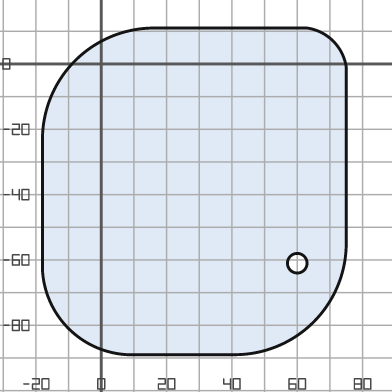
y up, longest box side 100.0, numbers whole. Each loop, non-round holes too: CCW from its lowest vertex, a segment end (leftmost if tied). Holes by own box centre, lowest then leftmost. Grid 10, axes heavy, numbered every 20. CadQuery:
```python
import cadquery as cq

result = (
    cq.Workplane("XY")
    .moveTo(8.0, -89.0)
    .lineTo(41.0, -89.0)
    .threePointArc((65.0, -79.0), (75.0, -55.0))
    .lineTo(75.0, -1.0)
    .threePointArc((71.0, 7.0), (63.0, 11.0))
    .lineTo(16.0, 11.0)
    .threePointArc((-8.0, 1.0), (-18.0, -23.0))
    .lineTo(-18.0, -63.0)
    .threePointArc((-10.0, -81.0), (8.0, -89.0))
    .close()
    .moveTo(60.0, -61.0)
    .circle(3.0)
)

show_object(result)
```